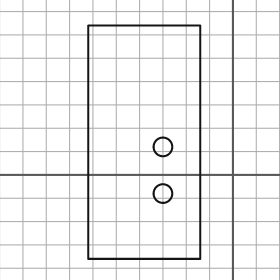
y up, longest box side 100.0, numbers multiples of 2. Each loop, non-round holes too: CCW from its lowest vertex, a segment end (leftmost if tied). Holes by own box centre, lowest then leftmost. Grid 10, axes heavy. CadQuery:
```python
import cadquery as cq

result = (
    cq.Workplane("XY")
    .moveTo(-62.0, -36.0)
    .lineTo(-14.0, -36.0)
    .lineTo(-14.0, 64.0)
    .lineTo(-62.0, 64.0)
    .close()
    .moveTo(-30.0, -8.0)
    .circle(4.0)
    .moveTo(-30.0, 12.0)
    .circle(4.0)
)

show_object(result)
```